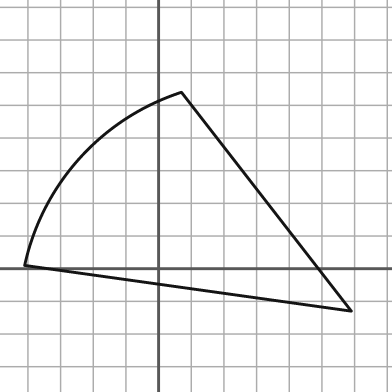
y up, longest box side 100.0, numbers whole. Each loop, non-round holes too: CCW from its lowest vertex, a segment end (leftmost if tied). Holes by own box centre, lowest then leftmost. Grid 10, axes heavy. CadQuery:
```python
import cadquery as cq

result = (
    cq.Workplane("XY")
    .moveTo(59.0, -13.0)
    .lineTo(7.0, 54.0)
    .threePointArc((-24.0, 34.0), (-41.0, 1.0))
    .close()
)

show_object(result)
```